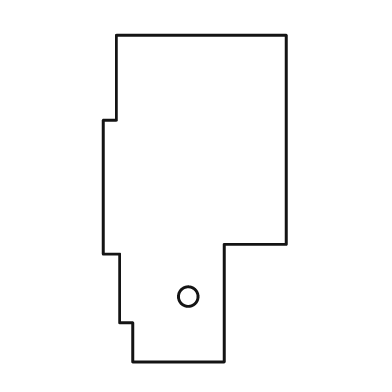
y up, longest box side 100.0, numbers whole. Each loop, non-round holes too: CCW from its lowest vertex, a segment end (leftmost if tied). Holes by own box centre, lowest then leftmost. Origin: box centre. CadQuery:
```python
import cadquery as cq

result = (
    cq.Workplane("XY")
    .moveTo(-19.0, -50.0)
    .lineTo(9.0, -50.0)
    .lineTo(9.0, -14.0)
    .lineTo(28.0, -14.0)
    .lineTo(28.0, 50.0)
    .lineTo(-24.0, 50.0)
    .lineTo(-24.0, 24.0)
    .lineTo(-28.0, 24.0)
    .lineTo(-28.0, -17.0)
    .lineTo(-23.0, -17.0)
    .lineTo(-23.0, -38.0)
    .lineTo(-19.0, -38.0)
    .close()
    .moveTo(-2.0, -30.0)
    .circle(3.0)
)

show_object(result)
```